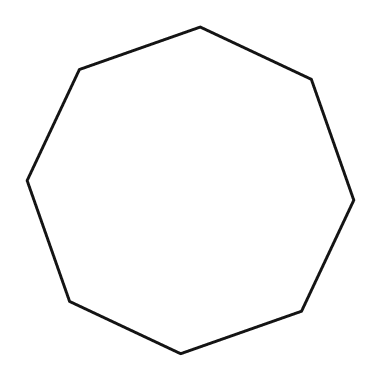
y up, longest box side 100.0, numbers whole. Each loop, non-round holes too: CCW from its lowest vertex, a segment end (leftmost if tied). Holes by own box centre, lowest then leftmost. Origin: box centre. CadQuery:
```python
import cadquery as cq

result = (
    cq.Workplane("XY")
    .moveTo(-3.0, -50.0)
    .lineTo(34.0, -37.0)
    .lineTo(50.0, -3.0)
    .lineTo(37.0, 34.0)
    .lineTo(3.0, 50.0)
    .lineTo(-34.0, 37.0)
    .lineTo(-50.0, 3.0)
    .lineTo(-37.0, -34.0)
    .close()
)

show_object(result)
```